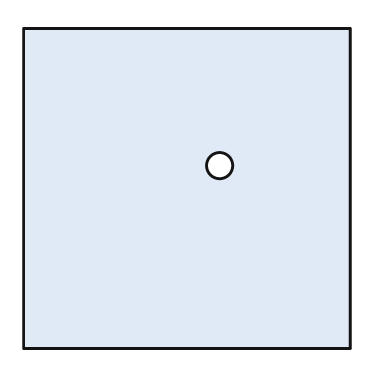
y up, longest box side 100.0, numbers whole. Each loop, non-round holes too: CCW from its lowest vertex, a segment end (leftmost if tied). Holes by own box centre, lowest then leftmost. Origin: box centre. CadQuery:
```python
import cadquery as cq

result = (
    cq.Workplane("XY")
    .moveTo(-50.0, -49.0)
    .lineTo(50.0, -49.0)
    .lineTo(50.0, 49.0)
    .lineTo(-50.0, 49.0)
    .close()
    .moveTo(10.0, 7.0)
    .circle(4.0)
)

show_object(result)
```